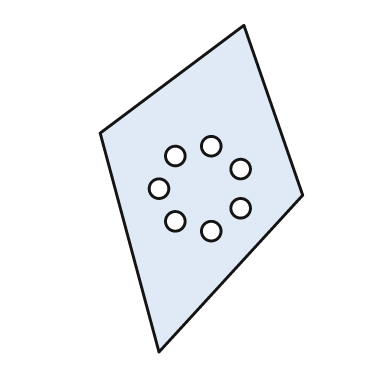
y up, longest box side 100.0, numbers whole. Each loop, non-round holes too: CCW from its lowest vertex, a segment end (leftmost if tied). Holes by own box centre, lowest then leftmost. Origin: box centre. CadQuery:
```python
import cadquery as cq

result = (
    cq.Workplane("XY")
    .moveTo(-13.0, -50.0)
    .lineTo(31.0, -2.0)
    .lineTo(13.0, 50.0)
    .lineTo(-31.0, 17.0)
    .close()
    .moveTo(3.0, -13.0)
    .circle(3.0)
    .moveTo(-8.0, -10.0)
    .circle(3.0)
    .moveTo(12.0, -6.0)
    .circle(3.0)
    .moveTo(-13.0, 0.0)
    .circle(3.0)
    .moveTo(12.0, 6.0)
    .circle(3.0)
    .moveTo(-8.0, 10.0)
    .circle(3.0)
    .moveTo(3.0, 13.0)
    .circle(3.0)
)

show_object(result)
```